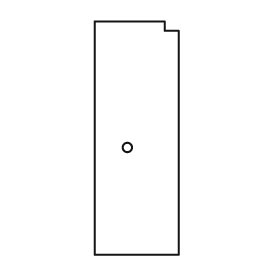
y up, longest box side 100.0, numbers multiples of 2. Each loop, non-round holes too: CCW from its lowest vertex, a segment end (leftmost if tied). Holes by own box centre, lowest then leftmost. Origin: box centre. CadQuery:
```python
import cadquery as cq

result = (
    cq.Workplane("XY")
    .moveTo(-18.0, -50.0)
    .lineTo(18.0, -50.0)
    .lineTo(18.0, 46.0)
    .lineTo(12.0, 46.0)
    .lineTo(12.0, 50.0)
    .lineTo(-18.0, 50.0)
    .close()
    .moveTo(-4.0, -4.0)
    .circle(2.0)
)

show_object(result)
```